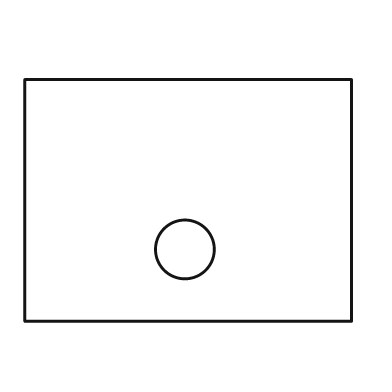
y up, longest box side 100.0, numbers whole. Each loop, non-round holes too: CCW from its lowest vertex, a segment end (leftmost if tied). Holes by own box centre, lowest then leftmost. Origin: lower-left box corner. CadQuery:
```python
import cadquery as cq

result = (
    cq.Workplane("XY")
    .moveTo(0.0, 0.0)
    .lineTo(100.0, 0.0)
    .lineTo(100.0, 74.0)
    .lineTo(0.0, 74.0)
    .close()
    .moveTo(49.0, 22.0)
    .circle(9.0)
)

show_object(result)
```